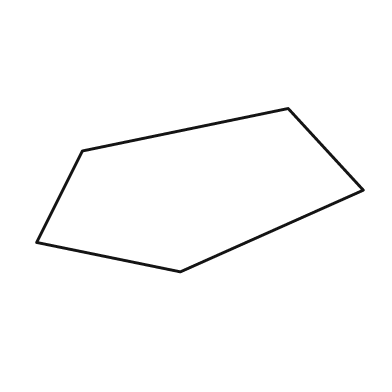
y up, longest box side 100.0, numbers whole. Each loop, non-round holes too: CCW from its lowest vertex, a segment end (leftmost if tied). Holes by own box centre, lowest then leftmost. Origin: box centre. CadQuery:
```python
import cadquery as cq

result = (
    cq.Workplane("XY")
    .moveTo(-6.0, -25.0)
    .lineTo(50.0, 0.0)
    .lineTo(27.0, 25.0)
    .lineTo(-36.0, 12.0)
    .lineTo(-50.0, -16.0)
    .close()
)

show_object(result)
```